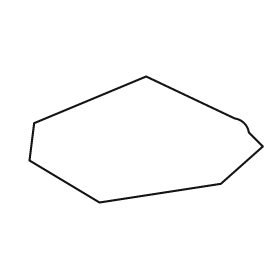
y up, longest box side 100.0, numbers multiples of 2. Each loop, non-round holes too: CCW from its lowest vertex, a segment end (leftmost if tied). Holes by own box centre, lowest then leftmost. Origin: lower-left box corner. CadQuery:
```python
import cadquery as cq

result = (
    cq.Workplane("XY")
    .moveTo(30.0, 0.0)
    .lineTo(82.0, 8.0)
    .lineTo(100.0, 24.0)
    .lineTo(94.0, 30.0)
    .threePointArc((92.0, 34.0), (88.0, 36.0))
    .lineTo(50.0, 54.0)
    .lineTo(2.0, 34.0)
    .lineTo(0.0, 18.0)
    .close()
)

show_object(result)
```